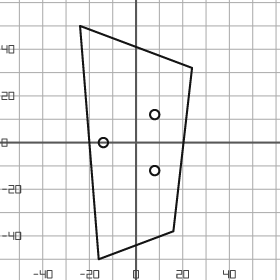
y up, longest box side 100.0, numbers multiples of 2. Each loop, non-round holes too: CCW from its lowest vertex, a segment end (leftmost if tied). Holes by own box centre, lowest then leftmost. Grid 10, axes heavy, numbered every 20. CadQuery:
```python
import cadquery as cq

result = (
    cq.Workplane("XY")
    .moveTo(-16.0, -50.0)
    .lineTo(16.0, -38.0)
    .lineTo(24.0, 32.0)
    .lineTo(-24.0, 50.0)
    .close()
    .moveTo(8.0, -12.0)
    .circle(2.0)
    .moveTo(-14.0, 0.0)
    .circle(2.0)
    .moveTo(8.0, 12.0)
    .circle(2.0)
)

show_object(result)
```